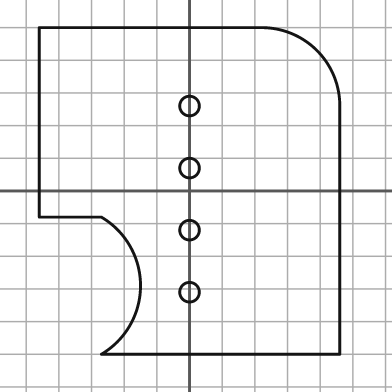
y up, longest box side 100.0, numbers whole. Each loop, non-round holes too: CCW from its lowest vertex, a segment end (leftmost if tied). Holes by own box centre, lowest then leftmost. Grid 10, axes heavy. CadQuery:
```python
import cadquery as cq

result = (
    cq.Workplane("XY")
    .moveTo(-27.0, -50.0)
    .lineTo(46.0, -50.0)
    .lineTo(46.0, 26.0)
    .threePointArc((39.0, 43.0), (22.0, 50.0))
    .lineTo(-46.0, 50.0)
    .lineTo(-46.0, -8.0)
    .lineTo(-27.0, -8.0)
    .threePointArc((-15.0, -29.0), (-27.0, -50.0))
    .close()
    .moveTo(0.0, -31.0)
    .circle(3.0)
    .moveTo(0.0, -12.0)
    .circle(3.0)
    .moveTo(0.0, 7.0)
    .circle(3.0)
    .moveTo(0.0, 26.0)
    .circle(3.0)
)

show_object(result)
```